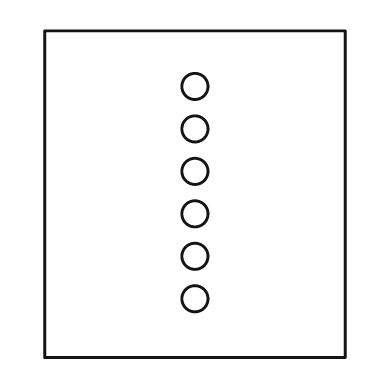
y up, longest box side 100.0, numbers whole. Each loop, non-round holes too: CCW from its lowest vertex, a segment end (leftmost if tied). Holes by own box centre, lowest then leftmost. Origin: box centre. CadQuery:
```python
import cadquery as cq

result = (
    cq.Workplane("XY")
    .moveTo(-46.0, -50.0)
    .lineTo(46.0, -50.0)
    .lineTo(46.0, 50.0)
    .lineTo(-46.0, 50.0)
    .close()
    .moveTo(0.0, -32.0)
    .circle(4.0)
    .moveTo(0.0, -19.0)
    .circle(4.0)
    .moveTo(0.0, -6.0)
    .circle(4.0)
    .moveTo(0.0, 7.0)
    .circle(4.0)
    .moveTo(0.0, 20.0)
    .circle(4.0)
    .moveTo(0.0, 33.0)
    .circle(4.0)
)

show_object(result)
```